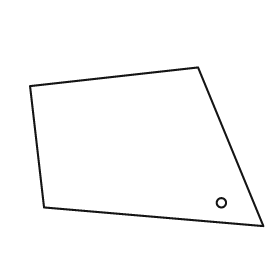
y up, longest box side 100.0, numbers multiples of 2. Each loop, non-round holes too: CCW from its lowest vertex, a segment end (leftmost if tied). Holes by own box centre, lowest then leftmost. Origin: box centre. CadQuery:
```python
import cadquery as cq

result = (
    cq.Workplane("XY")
    .moveTo(50.0, -34.0)
    .lineTo(22.0, 34.0)
    .lineTo(-50.0, 26.0)
    .lineTo(-44.0, -26.0)
    .close()
    .moveTo(32.0, -24.0)
    .circle(2.0)
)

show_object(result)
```